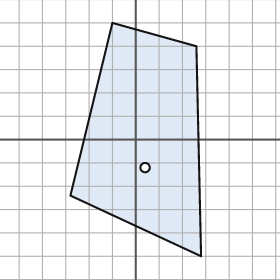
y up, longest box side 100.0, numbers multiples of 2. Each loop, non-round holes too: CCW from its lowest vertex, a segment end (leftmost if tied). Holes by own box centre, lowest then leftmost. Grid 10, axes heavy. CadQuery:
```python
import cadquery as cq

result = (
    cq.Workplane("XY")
    .moveTo(28.0, -50.0)
    .lineTo(26.0, 40.0)
    .lineTo(-10.0, 50.0)
    .lineTo(-28.0, -24.0)
    .close()
    .moveTo(4.0, -12.0)
    .circle(2.0)
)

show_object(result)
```